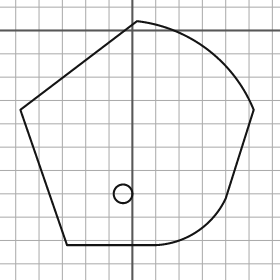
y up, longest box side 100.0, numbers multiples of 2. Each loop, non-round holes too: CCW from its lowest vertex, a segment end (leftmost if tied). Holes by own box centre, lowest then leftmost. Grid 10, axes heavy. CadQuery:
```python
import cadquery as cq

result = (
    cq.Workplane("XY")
    .moveTo(-28.0, -92.0)
    .lineTo(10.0, -92.0)
    .threePointArc((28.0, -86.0), (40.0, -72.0))
    .lineTo(52.0, -34.0)
    .threePointArc((32.0, -8.0), (2.0, 4.0))
    .lineTo(-48.0, -34.0)
    .close()
    .moveTo(-4.0, -70.0)
    .circle(4.0)
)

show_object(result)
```